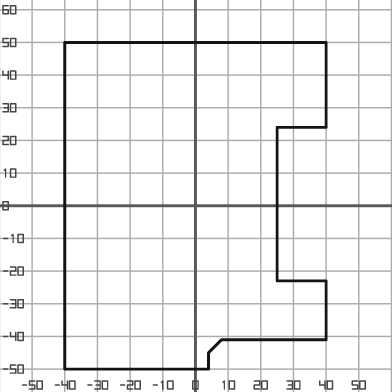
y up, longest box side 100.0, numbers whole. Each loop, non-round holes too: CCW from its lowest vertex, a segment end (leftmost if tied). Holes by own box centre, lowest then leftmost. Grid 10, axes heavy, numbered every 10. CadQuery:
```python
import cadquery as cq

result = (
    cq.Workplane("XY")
    .moveTo(-40.0, -50.0)
    .lineTo(4.0, -50.0)
    .lineTo(4.0, -45.0)
    .lineTo(8.0, -41.0)
    .lineTo(40.0, -41.0)
    .lineTo(40.0, -23.0)
    .lineTo(25.0, -23.0)
    .lineTo(25.0, 24.0)
    .lineTo(40.0, 24.0)
    .lineTo(40.0, 50.0)
    .lineTo(-40.0, 50.0)
    .close()
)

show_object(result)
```